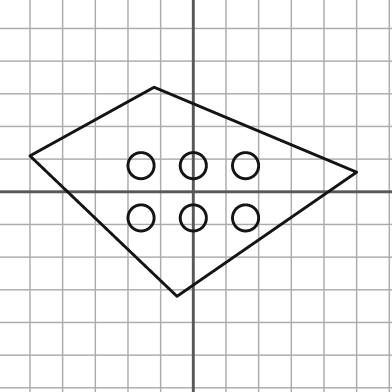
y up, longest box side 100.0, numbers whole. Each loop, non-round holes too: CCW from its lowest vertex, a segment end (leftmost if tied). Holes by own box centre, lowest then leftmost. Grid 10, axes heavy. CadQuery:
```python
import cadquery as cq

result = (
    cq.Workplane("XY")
    .moveTo(-5.0, -32.0)
    .lineTo(50.0, 6.0)
    .lineTo(-12.0, 32.0)
    .lineTo(-50.0, 11.0)
    .close()
    .moveTo(-16.0, -8.0)
    .circle(4.0)
    .moveTo(0.0, -8.0)
    .circle(4.0)
    .moveTo(16.0, -8.0)
    .circle(4.0)
    .moveTo(-16.0, 8.0)
    .circle(4.0)
    .moveTo(0.0, 8.0)
    .circle(4.0)
    .moveTo(16.0, 8.0)
    .circle(4.0)
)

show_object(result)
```